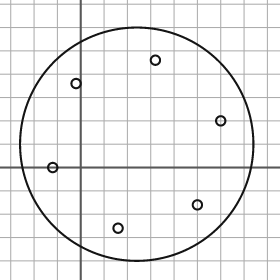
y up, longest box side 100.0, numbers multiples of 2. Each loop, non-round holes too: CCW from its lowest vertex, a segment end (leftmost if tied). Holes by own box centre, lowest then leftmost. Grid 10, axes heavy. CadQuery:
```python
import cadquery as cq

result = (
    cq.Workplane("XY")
    .moveTo(24.0, 10.0)
    .circle(50.0)
    .moveTo(16.0, -26.0)
    .circle(2.0)
    .moveTo(50.0, -16.0)
    .circle(2.0)
    .moveTo(-12.0, 0.0)
    .circle(2.0)
    .moveTo(60.0, 20.0)
    .circle(2.0)
    .moveTo(-2.0, 36.0)
    .circle(2.0)
    .moveTo(32.0, 46.0)
    .circle(2.0)
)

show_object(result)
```